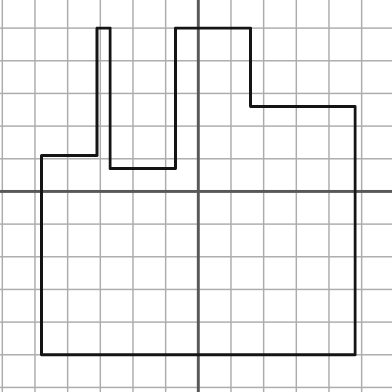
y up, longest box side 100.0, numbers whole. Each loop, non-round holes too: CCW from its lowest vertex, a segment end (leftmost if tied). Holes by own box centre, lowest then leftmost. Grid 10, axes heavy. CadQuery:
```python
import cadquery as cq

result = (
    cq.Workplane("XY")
    .moveTo(-48.0, -50.0)
    .lineTo(48.0, -50.0)
    .lineTo(48.0, 26.0)
    .lineTo(16.0, 26.0)
    .lineTo(16.0, 50.0)
    .lineTo(-7.0, 50.0)
    .lineTo(-7.0, 7.0)
    .lineTo(-27.0, 7.0)
    .lineTo(-27.0, 50.0)
    .lineTo(-31.0, 50.0)
    .lineTo(-31.0, 11.0)
    .lineTo(-48.0, 11.0)
    .close()
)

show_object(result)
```